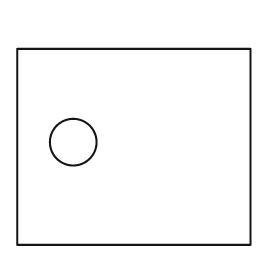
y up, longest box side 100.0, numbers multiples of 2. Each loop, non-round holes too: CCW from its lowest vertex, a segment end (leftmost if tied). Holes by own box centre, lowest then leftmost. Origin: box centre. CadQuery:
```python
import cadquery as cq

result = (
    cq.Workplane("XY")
    .moveTo(-50.0, -42.0)
    .lineTo(50.0, -42.0)
    .lineTo(50.0, 42.0)
    .lineTo(-50.0, 42.0)
    .close()
    .moveTo(-26.0, 2.0)
    .circle(10.0)
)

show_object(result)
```